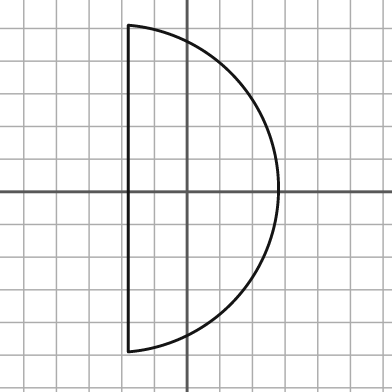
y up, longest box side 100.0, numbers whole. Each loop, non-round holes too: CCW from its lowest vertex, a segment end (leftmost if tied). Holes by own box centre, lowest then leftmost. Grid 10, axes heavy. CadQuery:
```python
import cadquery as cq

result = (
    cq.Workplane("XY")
    .moveTo(-18.0, -49.0)
    .threePointArc((28.0, 1.0), (-18.0, 51.0))
    .close()
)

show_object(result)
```